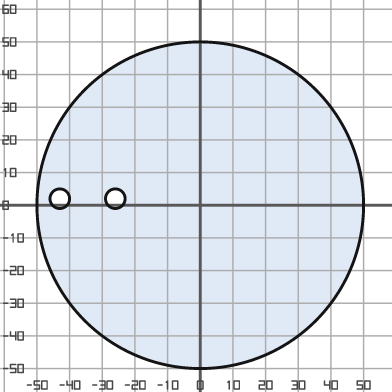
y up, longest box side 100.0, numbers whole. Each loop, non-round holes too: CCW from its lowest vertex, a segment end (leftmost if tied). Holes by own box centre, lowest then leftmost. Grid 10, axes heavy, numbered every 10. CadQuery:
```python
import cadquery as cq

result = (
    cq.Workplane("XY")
    .moveTo(0.0, 0.0)
    .circle(50.0)
    .moveTo(-43.0, 2.0)
    .circle(3.0)
    .moveTo(-26.0, 2.0)
    .circle(3.0)
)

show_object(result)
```